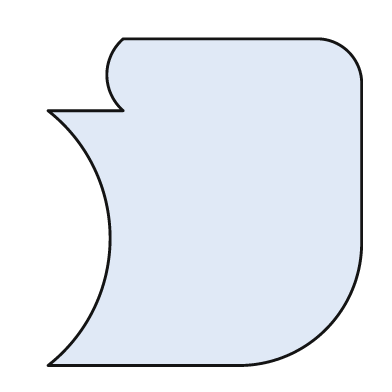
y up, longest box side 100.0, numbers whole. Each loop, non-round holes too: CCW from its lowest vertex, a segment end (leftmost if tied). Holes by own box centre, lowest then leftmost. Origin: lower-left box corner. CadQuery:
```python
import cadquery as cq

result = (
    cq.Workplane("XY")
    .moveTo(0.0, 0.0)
    .lineTo(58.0, 0.0)
    .threePointArc((85.0, 11.0), (96.0, 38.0))
    .lineTo(96.0, 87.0)
    .threePointArc((92.0, 96.0), (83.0, 100.0))
    .lineTo(23.0, 100.0)
    .threePointArc((18.0, 89.0), (23.0, 78.0))
    .lineTo(0.0, 78.0)
    .threePointArc((19.0, 39.0), (0.0, 0.0))
    .close()
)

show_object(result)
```